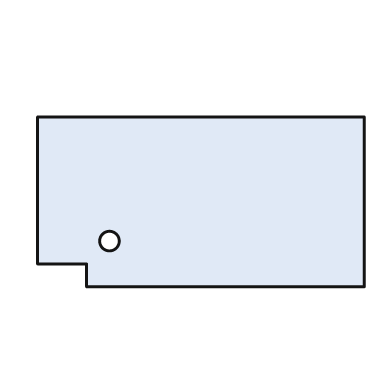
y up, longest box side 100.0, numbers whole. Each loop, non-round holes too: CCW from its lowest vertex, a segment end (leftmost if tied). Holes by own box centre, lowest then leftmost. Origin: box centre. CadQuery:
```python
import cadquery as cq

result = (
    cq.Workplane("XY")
    .moveTo(-35.0, -26.0)
    .lineTo(50.0, -26.0)
    .lineTo(50.0, 26.0)
    .lineTo(-50.0, 26.0)
    .lineTo(-50.0, -19.0)
    .lineTo(-35.0, -19.0)
    .close()
    .moveTo(-28.0, -12.0)
    .circle(3.0)
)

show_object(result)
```